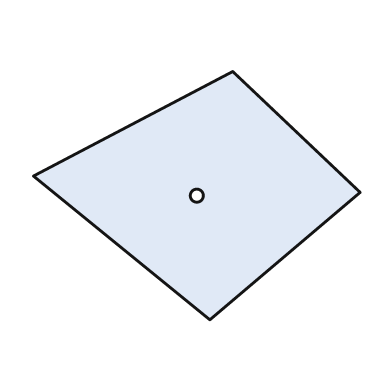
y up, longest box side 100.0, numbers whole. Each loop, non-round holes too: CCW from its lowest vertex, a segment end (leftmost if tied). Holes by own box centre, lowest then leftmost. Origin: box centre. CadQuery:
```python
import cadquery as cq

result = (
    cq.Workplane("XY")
    .moveTo(4.0, -38.0)
    .lineTo(50.0, 1.0)
    .lineTo(11.0, 38.0)
    .lineTo(-50.0, 6.0)
    .close()
    .moveTo(0.0, 0.0)
    .circle(2.0)
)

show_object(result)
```